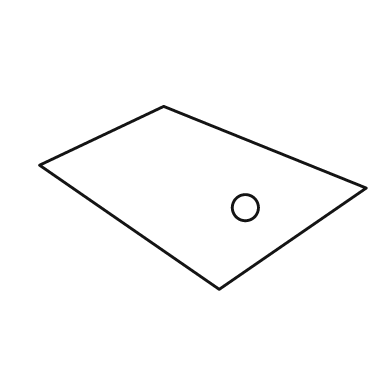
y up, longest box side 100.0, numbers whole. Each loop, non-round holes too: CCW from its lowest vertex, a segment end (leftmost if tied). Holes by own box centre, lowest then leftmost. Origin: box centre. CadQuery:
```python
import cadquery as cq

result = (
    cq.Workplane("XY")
    .moveTo(5.0, -28.0)
    .lineTo(50.0, 3.0)
    .lineTo(-12.0, 28.0)
    .lineTo(-50.0, 10.0)
    .close()
    .moveTo(13.0, -3.0)
    .circle(4.0)
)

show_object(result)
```